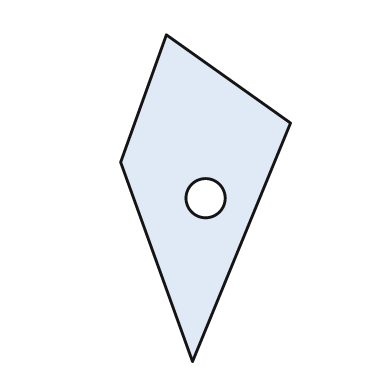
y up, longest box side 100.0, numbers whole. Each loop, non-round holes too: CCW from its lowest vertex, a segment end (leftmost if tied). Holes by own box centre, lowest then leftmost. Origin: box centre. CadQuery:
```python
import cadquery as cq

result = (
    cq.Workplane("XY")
    .moveTo(-4.0, -50.0)
    .lineTo(26.0, 23.0)
    .lineTo(-12.0, 50.0)
    .lineTo(-26.0, 11.0)
    .close()
    .moveTo(0.0, 0.0)
    .circle(6.0)
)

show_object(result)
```